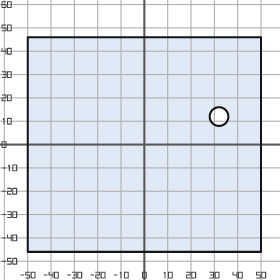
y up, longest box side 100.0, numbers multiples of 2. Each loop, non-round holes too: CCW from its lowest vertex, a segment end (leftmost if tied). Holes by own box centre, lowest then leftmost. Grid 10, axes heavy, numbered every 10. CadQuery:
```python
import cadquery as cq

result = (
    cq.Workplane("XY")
    .moveTo(-50.0, -46.0)
    .lineTo(50.0, -46.0)
    .lineTo(50.0, 46.0)
    .lineTo(-50.0, 46.0)
    .close()
    .moveTo(32.0, 12.0)
    .circle(4.0)
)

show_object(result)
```